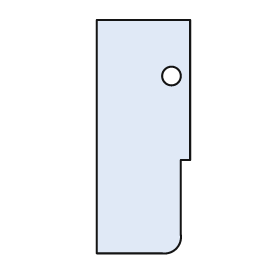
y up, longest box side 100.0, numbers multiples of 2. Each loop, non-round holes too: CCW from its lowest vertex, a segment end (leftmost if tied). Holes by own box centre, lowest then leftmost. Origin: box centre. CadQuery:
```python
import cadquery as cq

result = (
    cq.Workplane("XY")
    .moveTo(-20.0, -50.0)
    .lineTo(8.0, -50.0)
    .threePointArc((14.0, -48.0), (16.0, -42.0))
    .lineTo(16.0, -10.0)
    .lineTo(20.0, -10.0)
    .lineTo(20.0, 50.0)
    .lineTo(-20.0, 50.0)
    .close()
    .moveTo(12.0, 26.0)
    .circle(4.0)
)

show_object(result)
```